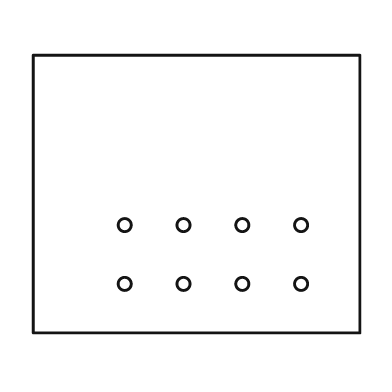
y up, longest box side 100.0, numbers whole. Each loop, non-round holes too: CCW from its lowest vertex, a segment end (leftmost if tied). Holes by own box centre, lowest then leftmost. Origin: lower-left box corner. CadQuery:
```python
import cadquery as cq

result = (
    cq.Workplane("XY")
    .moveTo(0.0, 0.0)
    .lineTo(100.0, 0.0)
    .lineTo(100.0, 85.0)
    .lineTo(0.0, 85.0)
    .close()
    .moveTo(28.0, 15.0)
    .circle(2.0)
    .moveTo(46.0, 15.0)
    .circle(2.0)
    .moveTo(64.0, 15.0)
    .circle(2.0)
    .moveTo(82.0, 15.0)
    .circle(2.0)
    .moveTo(28.0, 33.0)
    .circle(2.0)
    .moveTo(46.0, 33.0)
    .circle(2.0)
    .moveTo(64.0, 33.0)
    .circle(2.0)
    .moveTo(82.0, 33.0)
    .circle(2.0)
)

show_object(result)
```